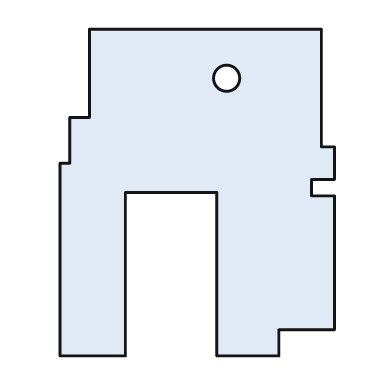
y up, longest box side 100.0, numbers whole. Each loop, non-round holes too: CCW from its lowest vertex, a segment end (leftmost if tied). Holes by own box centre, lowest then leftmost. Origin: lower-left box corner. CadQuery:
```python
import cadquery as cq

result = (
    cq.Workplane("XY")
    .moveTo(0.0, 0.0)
    .lineTo(20.0, 0.0)
    .lineTo(20.0, 50.0)
    .lineTo(48.0, 50.0)
    .lineTo(48.0, 0.0)
    .lineTo(67.0, 0.0)
    .lineTo(67.0, 8.0)
    .lineTo(84.0, 8.0)
    .lineTo(84.0, 49.0)
    .lineTo(77.0, 49.0)
    .lineTo(77.0, 54.0)
    .lineTo(84.0, 54.0)
    .lineTo(84.0, 64.0)
    .lineTo(80.0, 64.0)
    .lineTo(80.0, 100.0)
    .lineTo(9.0, 100.0)
    .lineTo(9.0, 73.0)
    .lineTo(3.0, 73.0)
    .lineTo(3.0, 59.0)
    .lineTo(0.0, 59.0)
    .close()
    .moveTo(51.0, 85.0)
    .circle(4.0)
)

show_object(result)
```